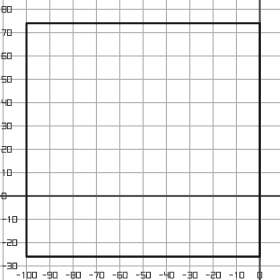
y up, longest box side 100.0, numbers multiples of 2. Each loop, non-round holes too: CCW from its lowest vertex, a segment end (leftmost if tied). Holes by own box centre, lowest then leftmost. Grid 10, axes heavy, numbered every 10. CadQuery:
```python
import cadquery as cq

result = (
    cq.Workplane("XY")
    .moveTo(-100.0, -26.0)
    .lineTo(0.0, -26.0)
    .lineTo(0.0, 74.0)
    .lineTo(-100.0, 74.0)
    .close()
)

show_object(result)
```